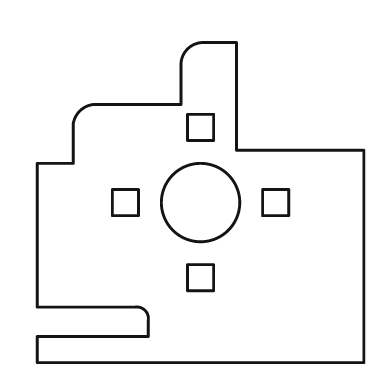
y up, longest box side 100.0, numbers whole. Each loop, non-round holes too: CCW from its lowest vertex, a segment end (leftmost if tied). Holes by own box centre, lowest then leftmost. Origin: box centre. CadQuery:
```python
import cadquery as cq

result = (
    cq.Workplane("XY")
    .moveTo(-50.0, -49.0)
    .lineTo(50.0, -49.0)
    .lineTo(50.0, 16.0)
    .lineTo(11.0, 16.0)
    .lineTo(11.0, 49.0)
    .lineTo(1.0, 49.0)
    .threePointArc((-4.0, 47.0), (-6.0, 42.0))
    .lineTo(-6.0, 30.0)
    .lineTo(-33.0, 30.0)
    .threePointArc((-37.0, 28.0), (-39.0, 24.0))
    .lineTo(-39.0, 12.0)
    .lineTo(-50.0, 12.0)
    .lineTo(-50.0, -32.0)
    .lineTo(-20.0, -32.0)
    .threePointArc((-17.0, -33.0), (-16.0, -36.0))
    .lineTo(-16.0, -41.0)
    .lineTo(-50.0, -41.0)
    .close()
    .moveTo(-4.0, -27.0)
    .lineTo(4.0, -27.0)
    .lineTo(4.0, -19.0)
    .lineTo(-4.0, -19.0)
    .close()
    .moveTo(-27.0, -4.0)
    .lineTo(-19.0, -4.0)
    .lineTo(-19.0, 4.0)
    .lineTo(-27.0, 4.0)
    .close()
    .moveTo(0.0, 0.0)
    .circle(12.0)
    .moveTo(19.0, -4.0)
    .lineTo(27.0, -4.0)
    .lineTo(27.0, 4.0)
    .lineTo(19.0, 4.0)
    .close()
    .moveTo(-4.0, 19.0)
    .lineTo(4.0, 19.0)
    .lineTo(4.0, 27.0)
    .lineTo(-4.0, 27.0)
    .close()
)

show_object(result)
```